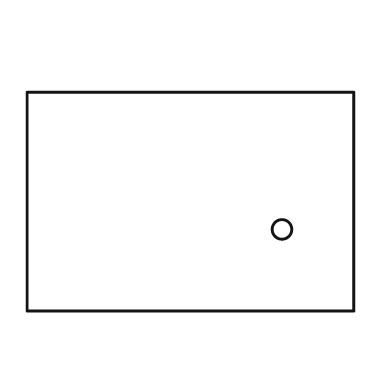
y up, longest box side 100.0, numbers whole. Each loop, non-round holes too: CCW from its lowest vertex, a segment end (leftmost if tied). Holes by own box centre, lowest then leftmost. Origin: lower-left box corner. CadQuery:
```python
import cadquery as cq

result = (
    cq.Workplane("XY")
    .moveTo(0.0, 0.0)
    .lineTo(100.0, 0.0)
    .lineTo(100.0, 67.0)
    .lineTo(0.0, 67.0)
    .close()
    .moveTo(78.0, 25.0)
    .circle(3.0)
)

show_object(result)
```